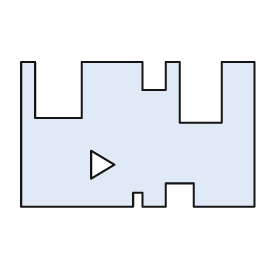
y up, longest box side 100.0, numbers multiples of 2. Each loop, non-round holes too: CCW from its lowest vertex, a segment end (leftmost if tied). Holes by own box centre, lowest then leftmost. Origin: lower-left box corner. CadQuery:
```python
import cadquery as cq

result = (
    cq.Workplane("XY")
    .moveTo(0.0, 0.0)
    .lineTo(48.0, 0.0)
    .lineTo(48.0, 6.0)
    .lineTo(52.0, 6.0)
    .lineTo(52.0, 0.0)
    .lineTo(62.0, 0.0)
    .lineTo(62.0, 10.0)
    .lineTo(74.0, 10.0)
    .lineTo(74.0, 0.0)
    .lineTo(100.0, 0.0)
    .lineTo(100.0, 62.0)
    .lineTo(86.0, 62.0)
    .lineTo(86.0, 36.0)
    .lineTo(68.0, 36.0)
    .lineTo(68.0, 62.0)
    .lineTo(62.0, 62.0)
    .lineTo(62.0, 50.0)
    .lineTo(52.0, 50.0)
    .lineTo(52.0, 62.0)
    .lineTo(26.0, 62.0)
    .lineTo(26.0, 38.0)
    .lineTo(6.0, 38.0)
    .lineTo(6.0, 62.0)
    .lineTo(0.0, 62.0)
    .close()
    .moveTo(30.0, 12.0)
    .lineTo(40.0, 18.0)
    .lineTo(30.0, 24.0)
    .close()
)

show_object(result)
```